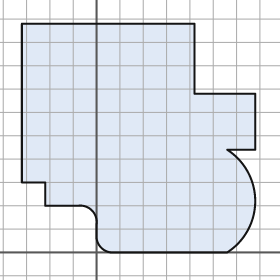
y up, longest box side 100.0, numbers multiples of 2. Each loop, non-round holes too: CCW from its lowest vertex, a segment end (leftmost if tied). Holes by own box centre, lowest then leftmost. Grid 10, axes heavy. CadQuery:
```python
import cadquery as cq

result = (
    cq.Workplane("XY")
    .moveTo(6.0, 0.0)
    .lineTo(56.0, 0.0)
    .threePointArc((68.0, 22.0), (56.0, 44.0))
    .lineTo(68.0, 44.0)
    .lineTo(68.0, 68.0)
    .lineTo(42.0, 68.0)
    .lineTo(42.0, 98.0)
    .lineTo(-32.0, 98.0)
    .lineTo(-32.0, 30.0)
    .lineTo(-22.0, 30.0)
    .lineTo(-22.0, 20.0)
    .lineTo(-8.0, 20.0)
    .threePointArc((-2.0, 18.0), (0.0, 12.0))
    .lineTo(0.0, 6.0)
    .threePointArc((2.0, 2.0), (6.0, 0.0))
    .close()
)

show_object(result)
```